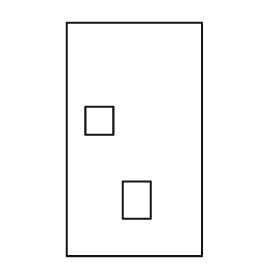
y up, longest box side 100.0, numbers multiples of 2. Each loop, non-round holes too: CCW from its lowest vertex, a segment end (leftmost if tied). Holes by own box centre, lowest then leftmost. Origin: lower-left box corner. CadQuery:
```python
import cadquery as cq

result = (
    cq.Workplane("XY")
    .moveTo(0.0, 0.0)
    .lineTo(58.0, 0.0)
    .lineTo(58.0, 100.0)
    .lineTo(0.0, 100.0)
    .close()
    .moveTo(24.0, 16.0)
    .lineTo(36.0, 16.0)
    .lineTo(36.0, 32.0)
    .lineTo(24.0, 32.0)
    .close()
    .moveTo(8.0, 52.0)
    .lineTo(20.0, 52.0)
    .lineTo(20.0, 64.0)
    .lineTo(8.0, 64.0)
    .close()
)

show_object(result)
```